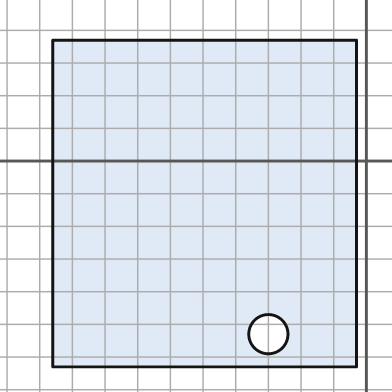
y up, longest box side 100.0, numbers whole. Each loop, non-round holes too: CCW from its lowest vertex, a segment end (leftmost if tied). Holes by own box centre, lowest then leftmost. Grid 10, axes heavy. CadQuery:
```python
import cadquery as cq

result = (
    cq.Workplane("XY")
    .moveTo(-96.0, -63.0)
    .lineTo(-3.0, -63.0)
    .lineTo(-3.0, 37.0)
    .lineTo(-96.0, 37.0)
    .close()
    .moveTo(-30.0, -53.0)
    .circle(6.0)
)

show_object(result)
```